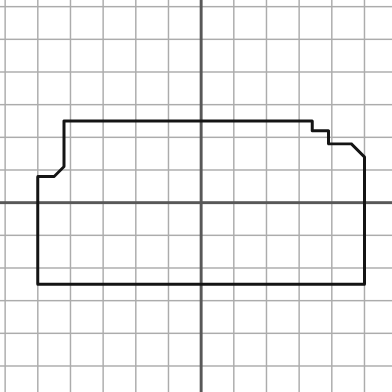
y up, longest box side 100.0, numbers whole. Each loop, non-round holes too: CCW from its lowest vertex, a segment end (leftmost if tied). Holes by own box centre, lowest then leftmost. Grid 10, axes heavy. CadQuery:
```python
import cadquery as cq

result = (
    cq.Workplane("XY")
    .moveTo(-50.0, -25.0)
    .lineTo(50.0, -25.0)
    .lineTo(50.0, 14.0)
    .lineTo(46.0, 18.0)
    .lineTo(39.0, 18.0)
    .lineTo(39.0, 22.0)
    .lineTo(34.0, 22.0)
    .lineTo(34.0, 25.0)
    .lineTo(-42.0, 25.0)
    .lineTo(-42.0, 11.0)
    .lineTo(-45.0, 8.0)
    .lineTo(-50.0, 8.0)
    .close()
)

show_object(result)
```